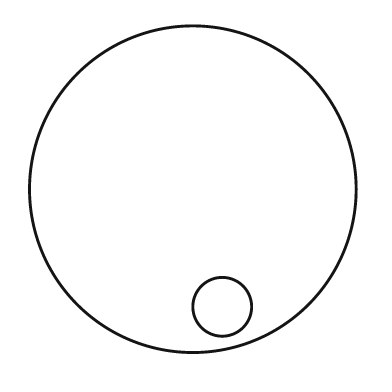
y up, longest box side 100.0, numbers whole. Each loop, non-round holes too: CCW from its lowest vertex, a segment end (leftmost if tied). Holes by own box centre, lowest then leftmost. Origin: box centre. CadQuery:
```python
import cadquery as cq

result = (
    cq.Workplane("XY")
    .moveTo(0.0, 0.0)
    .circle(50.0)
    .moveTo(9.0, -36.0)
    .circle(9.0)
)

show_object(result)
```